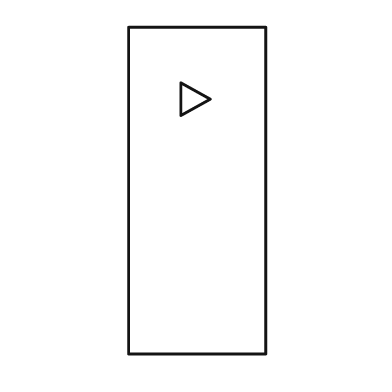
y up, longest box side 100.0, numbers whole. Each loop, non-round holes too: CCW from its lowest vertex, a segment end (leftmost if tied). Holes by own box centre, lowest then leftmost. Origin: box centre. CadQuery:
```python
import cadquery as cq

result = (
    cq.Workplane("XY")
    .moveTo(-21.0, -50.0)
    .lineTo(21.0, -50.0)
    .lineTo(21.0, 50.0)
    .lineTo(-21.0, 50.0)
    .close()
    .moveTo(-5.0, 23.0)
    .lineTo(4.0, 28.0)
    .lineTo(-5.0, 33.0)
    .close()
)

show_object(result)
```